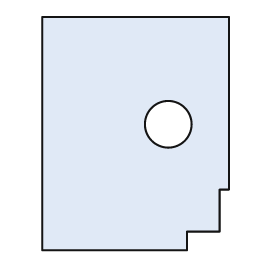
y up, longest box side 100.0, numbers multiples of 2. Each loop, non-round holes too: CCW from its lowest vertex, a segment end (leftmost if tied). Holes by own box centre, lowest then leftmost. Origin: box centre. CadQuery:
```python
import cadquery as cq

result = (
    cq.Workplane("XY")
    .moveTo(-40.0, -50.0)
    .lineTo(22.0, -50.0)
    .lineTo(22.0, -42.0)
    .lineTo(36.0, -42.0)
    .lineTo(36.0, -24.0)
    .lineTo(40.0, -24.0)
    .lineTo(40.0, 50.0)
    .lineTo(-40.0, 50.0)
    .close()
    .moveTo(14.0, 4.0)
    .circle(10.0)
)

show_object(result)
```